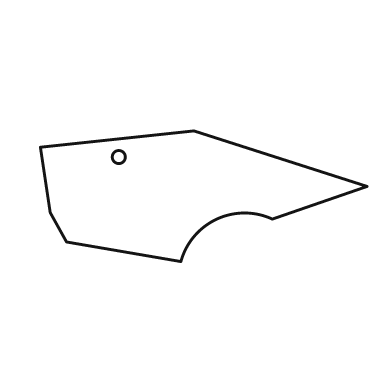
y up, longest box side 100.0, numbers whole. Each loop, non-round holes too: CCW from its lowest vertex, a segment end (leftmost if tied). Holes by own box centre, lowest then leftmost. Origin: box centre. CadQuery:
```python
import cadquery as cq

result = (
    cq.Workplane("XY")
    .moveTo(-7.0, -20.0)
    .threePointArc((4.0, -7.0), (21.0, -7.0))
    .lineTo(50.0, 3.0)
    .lineTo(-3.0, 20.0)
    .lineTo(-50.0, 15.0)
    .lineTo(-47.0, -5.0)
    .lineTo(-42.0, -14.0)
    .close()
    .moveTo(-26.0, 12.0)
    .circle(2.0)
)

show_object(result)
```